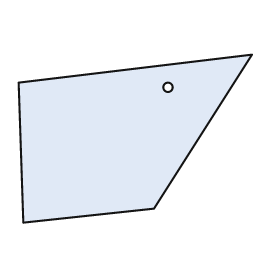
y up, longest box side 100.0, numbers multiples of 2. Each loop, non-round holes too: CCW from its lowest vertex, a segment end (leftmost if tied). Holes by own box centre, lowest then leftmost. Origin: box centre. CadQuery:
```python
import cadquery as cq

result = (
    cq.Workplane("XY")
    .moveTo(-48.0, -36.0)
    .lineTo(8.0, -30.0)
    .lineTo(50.0, 36.0)
    .lineTo(-50.0, 24.0)
    .close()
    .moveTo(14.0, 22.0)
    .circle(2.0)
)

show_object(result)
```